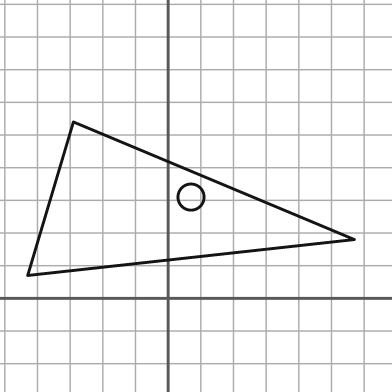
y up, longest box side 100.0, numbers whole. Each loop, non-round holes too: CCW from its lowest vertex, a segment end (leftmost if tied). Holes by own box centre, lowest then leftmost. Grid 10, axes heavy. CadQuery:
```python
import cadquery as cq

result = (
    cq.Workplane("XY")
    .moveTo(-43.0, 7.0)
    .lineTo(57.0, 18.0)
    .lineTo(-29.0, 54.0)
    .close()
    .moveTo(7.0, 31.0)
    .circle(4.0)
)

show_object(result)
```